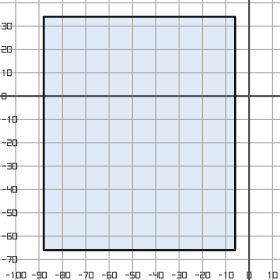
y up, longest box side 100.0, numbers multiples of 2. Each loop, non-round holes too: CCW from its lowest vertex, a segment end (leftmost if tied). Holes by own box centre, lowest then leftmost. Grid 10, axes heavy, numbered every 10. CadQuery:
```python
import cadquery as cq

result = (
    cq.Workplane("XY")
    .moveTo(-88.0, -66.0)
    .lineTo(-6.0, -66.0)
    .lineTo(-6.0, 34.0)
    .lineTo(-88.0, 34.0)
    .close()
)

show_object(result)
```